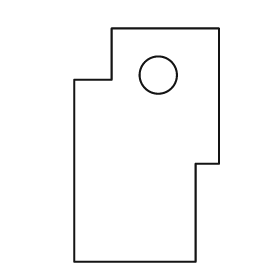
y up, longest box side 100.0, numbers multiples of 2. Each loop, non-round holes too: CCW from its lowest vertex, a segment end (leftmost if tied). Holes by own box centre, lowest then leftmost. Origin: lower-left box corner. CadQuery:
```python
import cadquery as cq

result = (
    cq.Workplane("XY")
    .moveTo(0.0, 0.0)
    .lineTo(52.0, 0.0)
    .lineTo(52.0, 42.0)
    .lineTo(62.0, 42.0)
    .lineTo(62.0, 100.0)
    .lineTo(16.0, 100.0)
    .lineTo(16.0, 78.0)
    .lineTo(0.0, 78.0)
    .close()
    .moveTo(36.0, 80.0)
    .circle(8.0)
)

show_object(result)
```